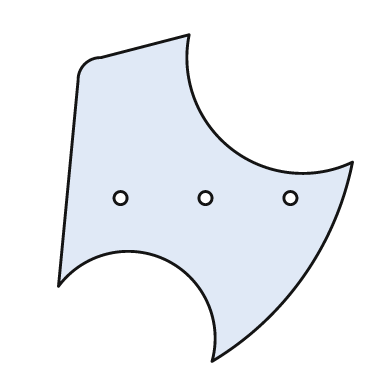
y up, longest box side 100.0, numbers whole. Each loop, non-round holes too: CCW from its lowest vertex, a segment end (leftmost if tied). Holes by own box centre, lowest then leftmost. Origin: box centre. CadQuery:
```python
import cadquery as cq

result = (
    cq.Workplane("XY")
    .moveTo(2.0, -50.0)
    .threePointArc((30.0, -24.0), (45.0, 11.0))
    .threePointArc((8.0, 15.0), (-5.0, 50.0))
    .lineTo(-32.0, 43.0)
    .threePointArc((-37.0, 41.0), (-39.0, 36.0))
    .lineTo(-45.0, -27.0)
    .threePointArc((-12.0, -19.0), (2.0, -50.0))
    .close()
    .moveTo(-26.0, 0.0)
    .circle(2.0)
    .moveTo(0.0, 0.0)
    .circle(2.0)
    .moveTo(26.0, 0.0)
    .circle(2.0)
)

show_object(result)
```